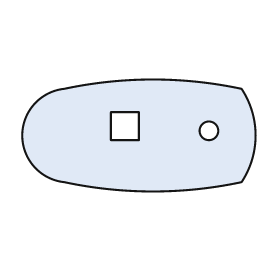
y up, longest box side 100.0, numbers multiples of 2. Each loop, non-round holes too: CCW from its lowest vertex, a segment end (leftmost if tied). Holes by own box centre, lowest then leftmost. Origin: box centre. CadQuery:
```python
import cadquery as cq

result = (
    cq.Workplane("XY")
    .moveTo(-32.0, -20.0)
    .threePointArc((6.0, -24.0), (44.0, -20.0))
    .threePointArc((50.0, 0.0), (44.0, 20.0))
    .threePointArc((6.0, 24.0), (-32.0, 20.0))
    .threePointArc((-50.0, 0.0), (-32.0, -20.0))
    .close()
    .moveTo(30.0, 2.0)
    .circle(4.0)
    .moveTo(-12.0, -2.0)
    .lineTo(0.0, -2.0)
    .lineTo(0.0, 10.0)
    .lineTo(-12.0, 10.0)
    .close()
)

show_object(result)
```